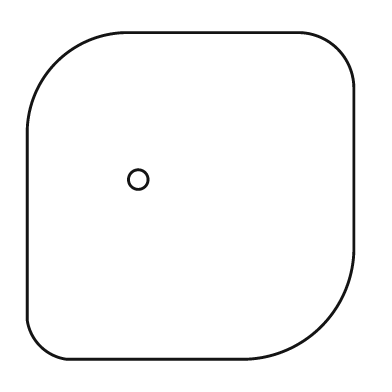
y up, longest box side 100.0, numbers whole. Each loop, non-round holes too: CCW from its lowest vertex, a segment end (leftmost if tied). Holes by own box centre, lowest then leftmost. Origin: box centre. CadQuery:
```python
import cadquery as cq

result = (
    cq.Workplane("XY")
    .moveTo(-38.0, -50.0)
    .lineTo(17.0, -50.0)
    .threePointArc((40.0, -40.0), (50.0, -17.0))
    .lineTo(50.0, 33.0)
    .threePointArc((45.0, 45.0), (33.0, 50.0))
    .lineTo(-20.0, 50.0)
    .threePointArc((-41.0, 41.0), (-50.0, 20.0))
    .lineTo(-50.0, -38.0)
    .threePointArc((-46.0, -46.0), (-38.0, -50.0))
    .close()
    .moveTo(-16.0, 5.0)
    .circle(3.0)
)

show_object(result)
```